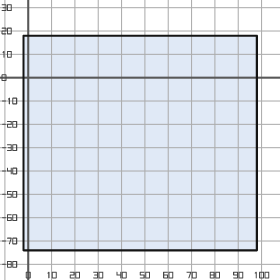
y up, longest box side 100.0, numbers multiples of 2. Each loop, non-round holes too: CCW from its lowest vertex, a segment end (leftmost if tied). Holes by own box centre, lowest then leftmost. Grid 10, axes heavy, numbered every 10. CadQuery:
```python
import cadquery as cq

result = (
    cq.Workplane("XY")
    .moveTo(-2.0, -74.0)
    .lineTo(98.0, -74.0)
    .lineTo(98.0, 18.0)
    .lineTo(-2.0, 18.0)
    .close()
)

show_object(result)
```